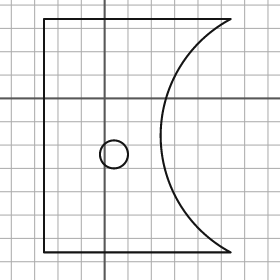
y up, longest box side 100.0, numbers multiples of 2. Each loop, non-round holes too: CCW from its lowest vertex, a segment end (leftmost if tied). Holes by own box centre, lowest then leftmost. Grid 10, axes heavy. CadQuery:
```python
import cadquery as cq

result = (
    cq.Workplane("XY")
    .moveTo(-26.0, -66.0)
    .lineTo(54.0, -66.0)
    .threePointArc((24.0, -16.0), (54.0, 34.0))
    .lineTo(-26.0, 34.0)
    .close()
    .moveTo(4.0, -24.0)
    .circle(6.0)
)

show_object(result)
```